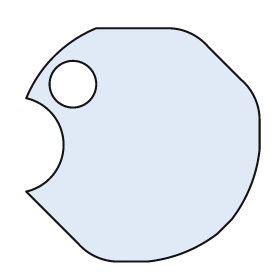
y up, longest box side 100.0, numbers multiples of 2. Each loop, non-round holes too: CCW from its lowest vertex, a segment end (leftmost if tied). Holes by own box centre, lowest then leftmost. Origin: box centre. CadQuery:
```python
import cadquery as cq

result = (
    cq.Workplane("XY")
    .moveTo(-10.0, -50.0)
    .lineTo(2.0, -50.0)
    .threePointArc((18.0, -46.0), (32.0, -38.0))
    .lineTo(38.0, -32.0)
    .threePointArc((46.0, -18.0), (50.0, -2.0))
    .lineTo(50.0, 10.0)
    .threePointArc((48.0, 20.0), (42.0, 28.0))
    .lineTo(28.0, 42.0)
    .threePointArc((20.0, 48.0), (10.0, 50.0))
    .lineTo(-20.0, 50.0)
    .threePointArc((-38.0, 38.0), (-50.0, 20.0))
    .threePointArc((-34.0, 0.0), (-50.0, -20.0))
    .lineTo(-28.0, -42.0)
    .threePointArc((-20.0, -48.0), (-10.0, -50.0))
    .close()
    .moveTo(-30.0, 26.0)
    .circle(10.0)
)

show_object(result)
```